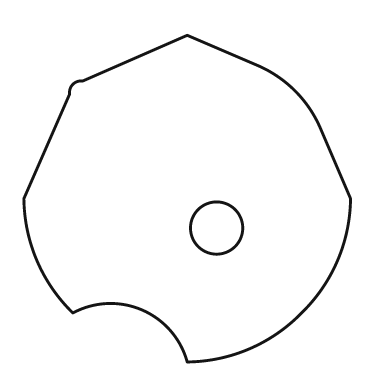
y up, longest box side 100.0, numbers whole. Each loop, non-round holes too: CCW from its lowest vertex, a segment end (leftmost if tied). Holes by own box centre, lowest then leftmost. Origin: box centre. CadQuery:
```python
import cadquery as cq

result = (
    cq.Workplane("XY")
    .moveTo(0.0, -50.0)
    .threePointArc((19.0, -46.0), (35.0, -35.0))
    .threePointArc((46.0, -19.0), (50.0, 0.0))
    .lineTo(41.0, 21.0)
    .threePointArc((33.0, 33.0), (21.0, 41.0))
    .lineTo(0.0, 50.0)
    .lineTo(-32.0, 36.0)
    .threePointArc((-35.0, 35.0), (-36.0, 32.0))
    .lineTo(-50.0, 0.0)
    .threePointArc((-46.0, -19.0), (-35.0, -35.0))
    .threePointArc((-14.0, -34.0), (0.0, -50.0))
    .close()
    .moveTo(9.0, -9.0)
    .circle(8.0)
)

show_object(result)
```